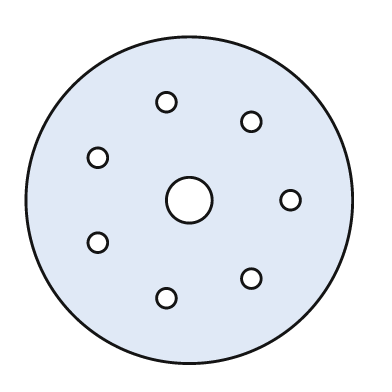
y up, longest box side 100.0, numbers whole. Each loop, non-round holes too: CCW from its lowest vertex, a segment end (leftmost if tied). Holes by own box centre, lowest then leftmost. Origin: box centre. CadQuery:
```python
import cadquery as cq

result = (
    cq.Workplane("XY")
    .moveTo(0.0, 0.0)
    .circle(50.0)
    .moveTo(-7.0, -30.0)
    .circle(3.0)
    .moveTo(19.0, -24.0)
    .circle(3.0)
    .moveTo(-28.0, -13.0)
    .circle(3.0)
    .moveTo(0.0, 0.0)
    .circle(7.0)
    .moveTo(31.0, 0.0)
    .circle(3.0)
    .moveTo(-28.0, 13.0)
    .circle(3.0)
    .moveTo(19.0, 24.0)
    .circle(3.0)
    .moveTo(-7.0, 30.0)
    .circle(3.0)
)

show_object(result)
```